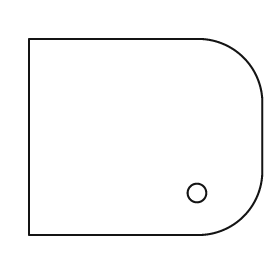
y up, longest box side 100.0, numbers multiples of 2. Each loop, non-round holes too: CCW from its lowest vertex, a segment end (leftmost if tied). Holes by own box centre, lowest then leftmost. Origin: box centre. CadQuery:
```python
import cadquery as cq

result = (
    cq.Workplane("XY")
    .moveTo(-50.0, -42.0)
    .lineTo(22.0, -42.0)
    .threePointArc((42.0, -34.0), (50.0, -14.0))
    .lineTo(50.0, 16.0)
    .threePointArc((42.0, 34.0), (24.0, 42.0))
    .lineTo(-50.0, 42.0)
    .close()
    .moveTo(22.0, -24.0)
    .circle(4.0)
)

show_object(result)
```